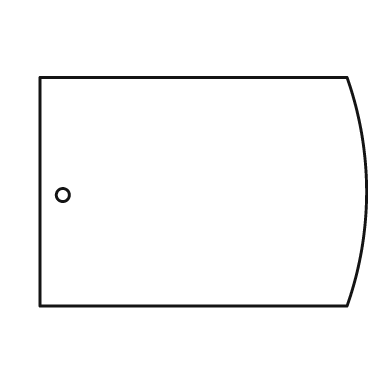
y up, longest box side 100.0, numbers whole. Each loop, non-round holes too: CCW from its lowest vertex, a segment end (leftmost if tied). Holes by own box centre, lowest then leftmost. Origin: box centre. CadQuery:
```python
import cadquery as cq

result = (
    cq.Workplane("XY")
    .moveTo(-50.0, -35.0)
    .lineTo(44.0, -35.0)
    .threePointArc((50.0, 0.0), (44.0, 35.0))
    .lineTo(-50.0, 35.0)
    .close()
    .moveTo(-43.0, -1.0)
    .circle(2.0)
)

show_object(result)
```